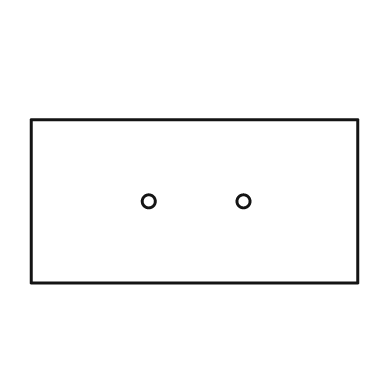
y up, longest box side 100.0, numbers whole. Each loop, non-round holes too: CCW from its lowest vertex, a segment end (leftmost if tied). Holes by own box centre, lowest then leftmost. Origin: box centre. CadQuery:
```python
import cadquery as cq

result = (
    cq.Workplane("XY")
    .moveTo(-50.0, -25.0)
    .lineTo(50.0, -25.0)
    .lineTo(50.0, 25.0)
    .lineTo(-50.0, 25.0)
    .close()
    .moveTo(-14.0, 0.0)
    .circle(2.0)
    .moveTo(15.0, 0.0)
    .circle(2.0)
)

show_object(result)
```